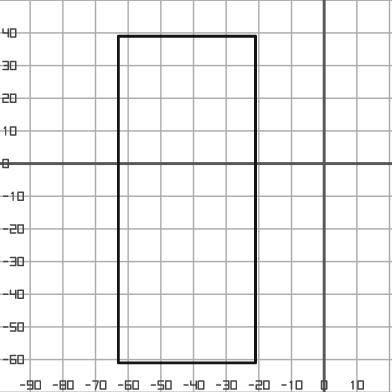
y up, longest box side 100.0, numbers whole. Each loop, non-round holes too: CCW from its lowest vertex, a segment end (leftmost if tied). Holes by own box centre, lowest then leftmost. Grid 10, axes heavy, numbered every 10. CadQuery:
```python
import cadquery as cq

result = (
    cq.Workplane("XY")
    .moveTo(-63.0, -61.0)
    .lineTo(-21.0, -61.0)
    .lineTo(-21.0, 39.0)
    .lineTo(-63.0, 39.0)
    .close()
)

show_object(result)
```